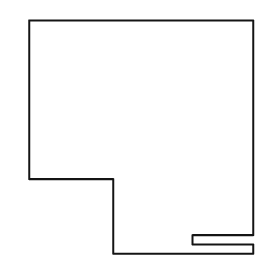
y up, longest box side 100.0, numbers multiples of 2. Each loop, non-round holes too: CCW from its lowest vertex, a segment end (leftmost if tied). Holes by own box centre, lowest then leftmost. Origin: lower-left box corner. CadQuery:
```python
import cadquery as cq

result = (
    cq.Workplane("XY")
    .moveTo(36.0, 0.0)
    .lineTo(96.0, 0.0)
    .lineTo(96.0, 4.0)
    .lineTo(70.0, 4.0)
    .lineTo(70.0, 8.0)
    .lineTo(96.0, 8.0)
    .lineTo(96.0, 100.0)
    .lineTo(0.0, 100.0)
    .lineTo(0.0, 32.0)
    .lineTo(36.0, 32.0)
    .close()
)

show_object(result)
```